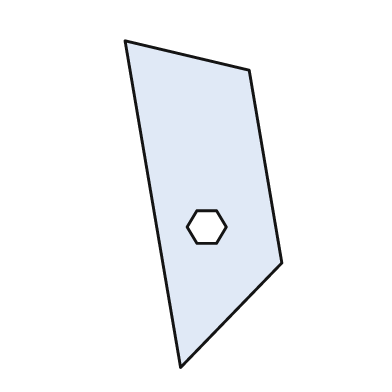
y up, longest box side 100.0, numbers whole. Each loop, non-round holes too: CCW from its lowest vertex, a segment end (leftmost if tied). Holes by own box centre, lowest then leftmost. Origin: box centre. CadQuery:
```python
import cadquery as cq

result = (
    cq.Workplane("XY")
    .moveTo(-7.0, -50.0)
    .lineTo(24.0, -18.0)
    .lineTo(14.0, 41.0)
    .lineTo(-24.0, 50.0)
    .close()
    .moveTo(-2.0, -12.0)
    .lineTo(4.0, -12.0)
    .lineTo(7.0, -7.0)
    .lineTo(4.0, -2.0)
    .lineTo(-2.0, -2.0)
    .lineTo(-5.0, -7.0)
    .close()
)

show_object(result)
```